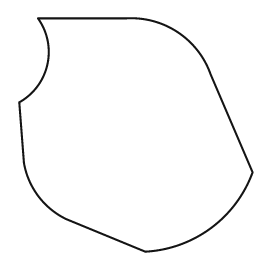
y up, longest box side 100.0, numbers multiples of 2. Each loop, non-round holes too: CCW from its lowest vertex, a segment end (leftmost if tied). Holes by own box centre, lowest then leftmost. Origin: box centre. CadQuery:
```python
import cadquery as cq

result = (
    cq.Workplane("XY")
    .moveTo(4.0, -50.0)
    .threePointArc((32.0, -40.0), (50.0, -16.0))
    .lineTo(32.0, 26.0)
    .threePointArc((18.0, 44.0), (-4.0, 50.0))
    .lineTo(-42.0, 50.0)
    .threePointArc((-38.0, 30.0), (-50.0, 14.0))
    .lineTo(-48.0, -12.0)
    .threePointArc((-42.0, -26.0), (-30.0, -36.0))
    .close()
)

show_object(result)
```